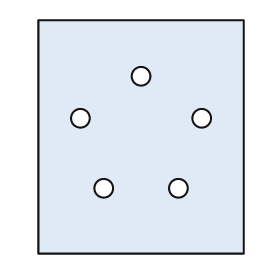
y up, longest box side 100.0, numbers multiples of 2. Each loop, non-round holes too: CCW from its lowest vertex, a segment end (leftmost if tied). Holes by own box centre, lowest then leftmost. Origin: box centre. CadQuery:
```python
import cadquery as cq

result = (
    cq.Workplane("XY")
    .moveTo(-44.0, -50.0)
    .lineTo(44.0, -50.0)
    .lineTo(44.0, 50.0)
    .lineTo(-44.0, 50.0)
    .close()
    .moveTo(-16.0, -22.0)
    .circle(4.0)
    .moveTo(16.0, -22.0)
    .circle(4.0)
    .moveTo(-26.0, 8.0)
    .circle(4.0)
    .moveTo(26.0, 8.0)
    .circle(4.0)
    .moveTo(0.0, 26.0)
    .circle(4.0)
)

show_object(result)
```